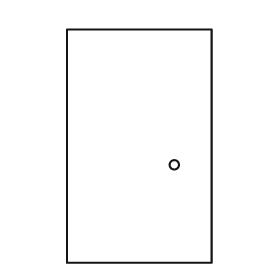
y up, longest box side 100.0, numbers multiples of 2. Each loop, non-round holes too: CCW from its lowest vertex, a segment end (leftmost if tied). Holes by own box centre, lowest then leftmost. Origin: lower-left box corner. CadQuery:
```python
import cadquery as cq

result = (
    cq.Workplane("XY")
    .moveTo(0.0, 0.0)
    .lineTo(62.0, 0.0)
    .lineTo(62.0, 100.0)
    .lineTo(0.0, 100.0)
    .close()
    .moveTo(46.0, 42.0)
    .circle(2.0)
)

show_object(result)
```